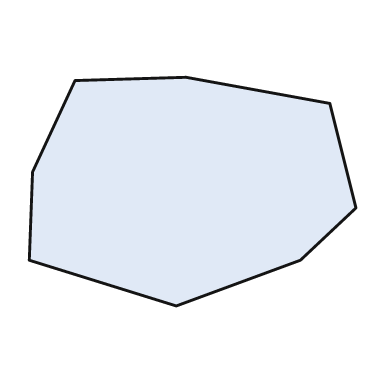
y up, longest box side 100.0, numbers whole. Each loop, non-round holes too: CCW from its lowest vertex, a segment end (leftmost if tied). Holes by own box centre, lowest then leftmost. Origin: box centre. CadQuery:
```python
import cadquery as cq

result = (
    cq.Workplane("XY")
    .moveTo(-5.0, -35.0)
    .lineTo(33.0, -21.0)
    .lineTo(50.0, -5.0)
    .lineTo(42.0, 27.0)
    .lineTo(-2.0, 35.0)
    .lineTo(-36.0, 34.0)
    .lineTo(-49.0, 6.0)
    .lineTo(-50.0, -21.0)
    .close()
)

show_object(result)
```